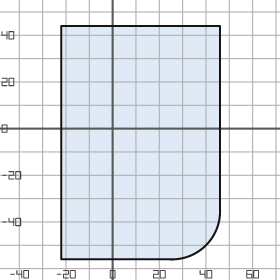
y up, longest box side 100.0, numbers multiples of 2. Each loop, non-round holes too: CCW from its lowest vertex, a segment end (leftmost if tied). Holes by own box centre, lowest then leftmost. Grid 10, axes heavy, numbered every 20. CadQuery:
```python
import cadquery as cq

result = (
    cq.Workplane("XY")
    .moveTo(-22.0, -56.0)
    .lineTo(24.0, -56.0)
    .threePointArc((40.0, -50.0), (46.0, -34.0))
    .lineTo(46.0, 44.0)
    .lineTo(-22.0, 44.0)
    .close()
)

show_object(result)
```